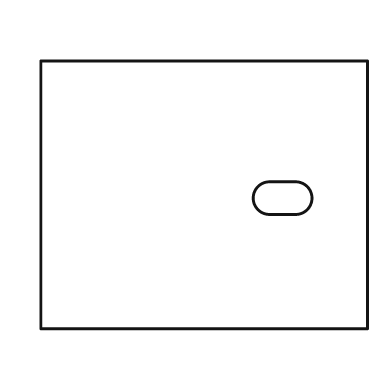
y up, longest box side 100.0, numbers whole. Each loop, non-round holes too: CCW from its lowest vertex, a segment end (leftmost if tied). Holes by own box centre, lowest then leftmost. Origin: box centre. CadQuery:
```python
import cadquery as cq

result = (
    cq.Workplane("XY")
    .moveTo(-50.0, -41.0)
    .lineTo(50.0, -41.0)
    .lineTo(50.0, 41.0)
    .lineTo(-50.0, 41.0)
    .close()
    .moveTo(20.0, -6.0)
    .lineTo(28.0, -6.0)
    .threePointArc((33.0, -1.0), (28.0, 4.0))
    .lineTo(20.0, 4.0)
    .threePointArc((15.0, -1.0), (20.0, -6.0))
    .close()
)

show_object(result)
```